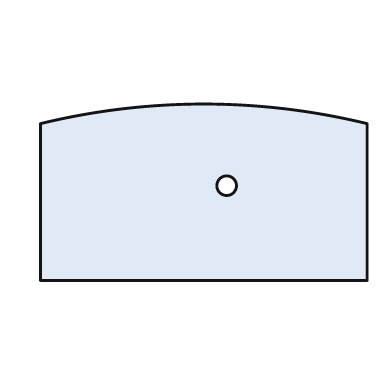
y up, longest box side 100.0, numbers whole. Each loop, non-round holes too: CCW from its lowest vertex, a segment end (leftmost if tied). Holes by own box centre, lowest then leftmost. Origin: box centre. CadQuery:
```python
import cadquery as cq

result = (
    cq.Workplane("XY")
    .moveTo(-50.0, -27.0)
    .lineTo(50.0, -27.0)
    .lineTo(50.0, 21.0)
    .threePointArc((0.0, 27.0), (-50.0, 21.0))
    .close()
    .moveTo(7.0, 2.0)
    .circle(3.0)
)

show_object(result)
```